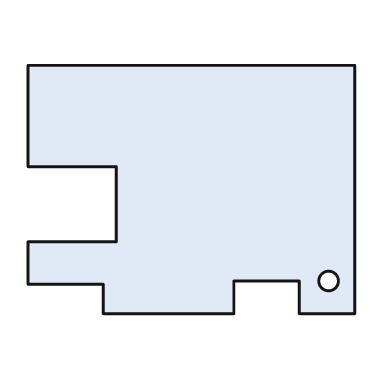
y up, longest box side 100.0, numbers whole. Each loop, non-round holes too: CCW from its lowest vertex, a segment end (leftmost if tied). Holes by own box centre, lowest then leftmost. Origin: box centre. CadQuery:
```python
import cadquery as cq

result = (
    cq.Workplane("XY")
    .moveTo(-27.0, -38.0)
    .lineTo(13.0, -38.0)
    .lineTo(13.0, -28.0)
    .lineTo(33.0, -28.0)
    .lineTo(33.0, -38.0)
    .lineTo(50.0, -38.0)
    .lineTo(50.0, 38.0)
    .lineTo(-50.0, 38.0)
    .lineTo(-50.0, 7.0)
    .lineTo(-23.0, 7.0)
    .lineTo(-23.0, -16.0)
    .lineTo(-50.0, -16.0)
    .lineTo(-50.0, -29.0)
    .lineTo(-27.0, -29.0)
    .close()
    .moveTo(42.0, -28.0)
    .circle(3.0)
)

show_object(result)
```